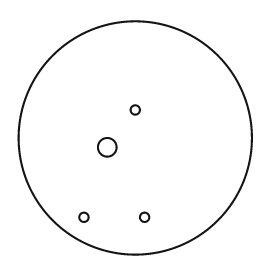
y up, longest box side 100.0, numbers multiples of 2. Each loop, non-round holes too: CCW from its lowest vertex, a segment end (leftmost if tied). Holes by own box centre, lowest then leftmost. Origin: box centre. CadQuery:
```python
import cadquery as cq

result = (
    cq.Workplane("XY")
    .moveTo(0.0, 0.0)
    .circle(50.0)
    .moveTo(-22.0, -34.0)
    .circle(2.0)
    .moveTo(4.0, -34.0)
    .circle(2.0)
    .moveTo(-12.0, -4.0)
    .circle(4.0)
    .moveTo(0.0, 12.0)
    .circle(2.0)
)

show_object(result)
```